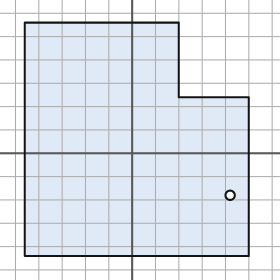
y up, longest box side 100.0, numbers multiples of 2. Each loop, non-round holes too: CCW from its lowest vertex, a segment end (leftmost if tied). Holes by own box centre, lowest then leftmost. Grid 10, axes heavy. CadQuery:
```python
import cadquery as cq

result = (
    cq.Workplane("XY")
    .moveTo(-46.0, -44.0)
    .lineTo(50.0, -44.0)
    .lineTo(50.0, 24.0)
    .lineTo(20.0, 24.0)
    .lineTo(20.0, 56.0)
    .lineTo(-46.0, 56.0)
    .close()
    .moveTo(42.0, -18.0)
    .circle(2.0)
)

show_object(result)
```